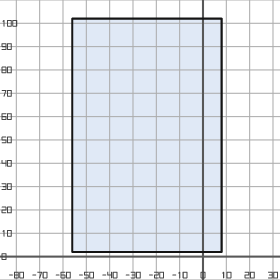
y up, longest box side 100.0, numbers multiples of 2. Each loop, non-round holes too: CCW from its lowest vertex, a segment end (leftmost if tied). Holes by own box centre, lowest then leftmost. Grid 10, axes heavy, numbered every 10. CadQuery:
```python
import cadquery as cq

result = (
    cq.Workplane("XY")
    .moveTo(-56.0, 2.0)
    .lineTo(8.0, 2.0)
    .lineTo(8.0, 102.0)
    .lineTo(-56.0, 102.0)
    .close()
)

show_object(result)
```